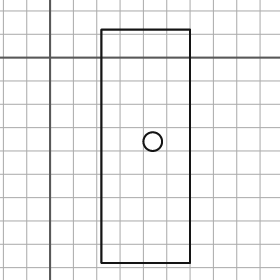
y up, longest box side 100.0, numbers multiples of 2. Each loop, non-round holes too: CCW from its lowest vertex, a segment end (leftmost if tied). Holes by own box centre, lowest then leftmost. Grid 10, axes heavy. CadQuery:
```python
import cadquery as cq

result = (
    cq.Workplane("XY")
    .moveTo(22.0, -88.0)
    .lineTo(60.0, -88.0)
    .lineTo(60.0, 12.0)
    .lineTo(22.0, 12.0)
    .close()
    .moveTo(44.0, -36.0)
    .circle(4.0)
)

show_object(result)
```